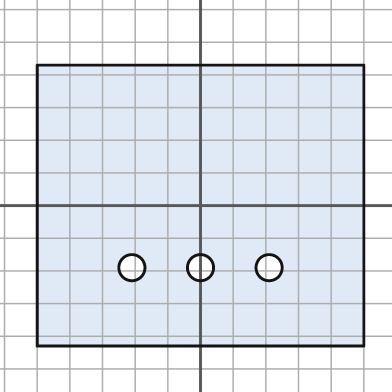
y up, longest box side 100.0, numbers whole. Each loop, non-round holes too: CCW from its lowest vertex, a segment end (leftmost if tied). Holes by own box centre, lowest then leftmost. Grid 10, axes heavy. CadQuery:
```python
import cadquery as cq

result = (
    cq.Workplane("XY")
    .moveTo(-50.0, -43.0)
    .lineTo(50.0, -43.0)
    .lineTo(50.0, 43.0)
    .lineTo(-50.0, 43.0)
    .close()
    .moveTo(-21.0, -19.0)
    .circle(4.0)
    .moveTo(0.0, -19.0)
    .circle(4.0)
    .moveTo(21.0, -19.0)
    .circle(4.0)
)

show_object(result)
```